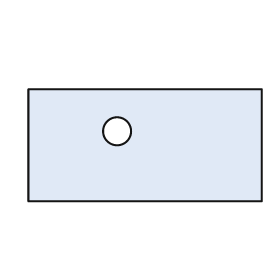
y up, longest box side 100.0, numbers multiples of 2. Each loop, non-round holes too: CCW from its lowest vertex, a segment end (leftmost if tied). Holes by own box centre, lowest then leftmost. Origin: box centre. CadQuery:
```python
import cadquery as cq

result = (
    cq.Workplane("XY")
    .moveTo(-50.0, -24.0)
    .lineTo(50.0, -24.0)
    .lineTo(50.0, 24.0)
    .lineTo(-50.0, 24.0)
    .close()
    .moveTo(-12.0, 6.0)
    .circle(6.0)
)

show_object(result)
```